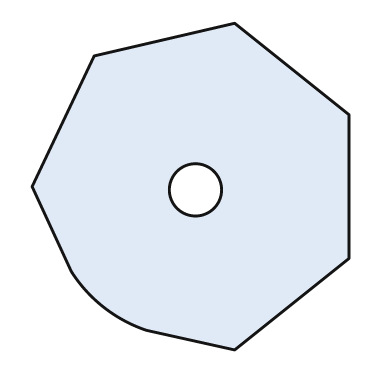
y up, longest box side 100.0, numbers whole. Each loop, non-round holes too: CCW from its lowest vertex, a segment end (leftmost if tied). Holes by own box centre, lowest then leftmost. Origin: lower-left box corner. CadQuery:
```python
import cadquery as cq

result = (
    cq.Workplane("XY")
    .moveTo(62.0, 0.0)
    .lineTo(97.0, 28.0)
    .lineTo(97.0, 72.0)
    .lineTo(62.0, 100.0)
    .lineTo(19.0, 90.0)
    .lineTo(0.0, 50.0)
    .lineTo(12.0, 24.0)
    .threePointArc((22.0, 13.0), (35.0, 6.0))
    .close()
    .moveTo(50.0, 49.0)
    .circle(8.0)
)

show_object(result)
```